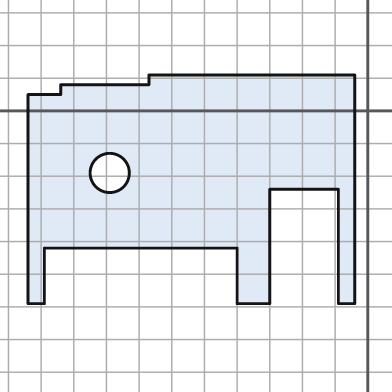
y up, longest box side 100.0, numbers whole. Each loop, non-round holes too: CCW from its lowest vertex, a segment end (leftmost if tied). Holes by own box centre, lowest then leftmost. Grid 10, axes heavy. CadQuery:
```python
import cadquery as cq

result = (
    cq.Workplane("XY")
    .moveTo(-104.0, -59.0)
    .lineTo(-99.0, -59.0)
    .lineTo(-99.0, -42.0)
    .lineTo(-40.0, -42.0)
    .lineTo(-40.0, -59.0)
    .lineTo(-30.0, -59.0)
    .lineTo(-30.0, -24.0)
    .lineTo(-9.0, -24.0)
    .lineTo(-9.0, -59.0)
    .lineTo(-4.0, -59.0)
    .lineTo(-4.0, 11.0)
    .lineTo(-67.0, 11.0)
    .lineTo(-67.0, 8.0)
    .lineTo(-94.0, 8.0)
    .lineTo(-94.0, 5.0)
    .lineTo(-104.0, 5.0)
    .close()
    .moveTo(-79.0, -19.0)
    .circle(6.0)
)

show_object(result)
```